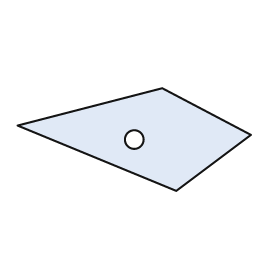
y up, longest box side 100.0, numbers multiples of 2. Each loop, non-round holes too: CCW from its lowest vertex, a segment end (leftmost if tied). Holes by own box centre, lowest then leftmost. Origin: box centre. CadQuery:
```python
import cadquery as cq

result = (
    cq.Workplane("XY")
    .moveTo(18.0, -22.0)
    .lineTo(50.0, 2.0)
    .lineTo(12.0, 22.0)
    .lineTo(-50.0, 6.0)
    .close()
    .moveTo(0.0, 0.0)
    .circle(4.0)
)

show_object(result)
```